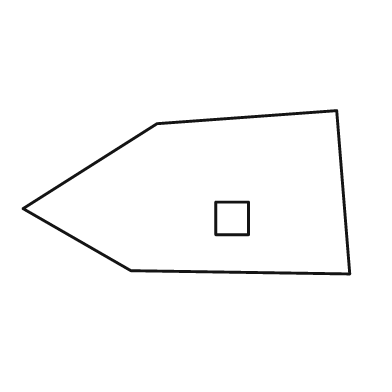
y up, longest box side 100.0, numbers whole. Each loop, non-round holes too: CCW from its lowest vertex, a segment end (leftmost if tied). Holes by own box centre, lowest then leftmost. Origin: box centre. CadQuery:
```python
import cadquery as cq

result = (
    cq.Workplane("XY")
    .moveTo(50.0, -25.0)
    .lineTo(46.0, 25.0)
    .lineTo(-9.0, 21.0)
    .lineTo(-50.0, -5.0)
    .lineTo(-17.0, -24.0)
    .close()
    .moveTo(9.0, -13.0)
    .lineTo(19.0, -13.0)
    .lineTo(19.0, -3.0)
    .lineTo(9.0, -3.0)
    .close()
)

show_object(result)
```